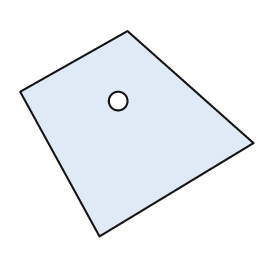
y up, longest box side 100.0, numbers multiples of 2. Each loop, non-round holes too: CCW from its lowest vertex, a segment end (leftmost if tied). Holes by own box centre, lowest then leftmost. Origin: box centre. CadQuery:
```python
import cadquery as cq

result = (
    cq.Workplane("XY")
    .moveTo(-16.0, -44.0)
    .lineTo(50.0, -4.0)
    .lineTo(-4.0, 44.0)
    .lineTo(-50.0, 18.0)
    .close()
    .moveTo(-8.0, 14.0)
    .circle(4.0)
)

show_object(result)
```